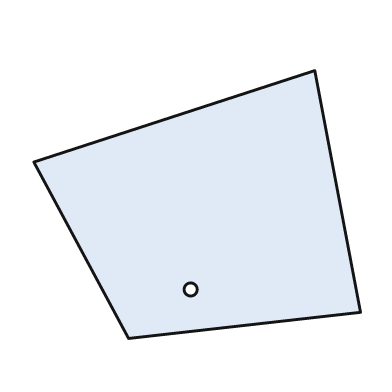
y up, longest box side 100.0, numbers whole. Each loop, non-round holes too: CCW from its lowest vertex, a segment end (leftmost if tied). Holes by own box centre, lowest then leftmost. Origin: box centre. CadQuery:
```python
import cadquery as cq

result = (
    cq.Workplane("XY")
    .moveTo(-21.0, -41.0)
    .lineTo(50.0, -33.0)
    .lineTo(36.0, 41.0)
    .lineTo(-50.0, 13.0)
    .close()
    .moveTo(-2.0, -26.0)
    .circle(2.0)
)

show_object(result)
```